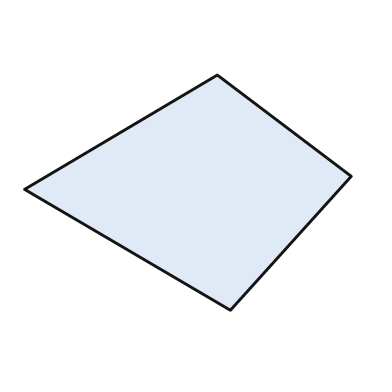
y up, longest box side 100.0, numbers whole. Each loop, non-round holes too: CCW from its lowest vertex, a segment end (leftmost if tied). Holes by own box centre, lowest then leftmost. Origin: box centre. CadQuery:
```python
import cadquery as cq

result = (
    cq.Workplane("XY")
    .moveTo(13.0, -36.0)
    .lineTo(50.0, 5.0)
    .lineTo(9.0, 36.0)
    .lineTo(-50.0, 1.0)
    .close()
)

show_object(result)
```